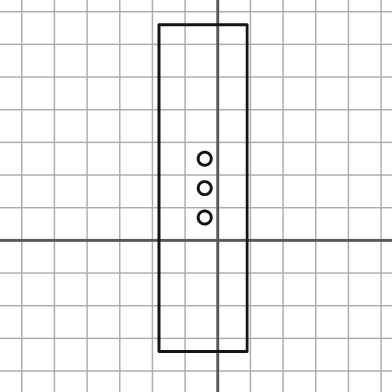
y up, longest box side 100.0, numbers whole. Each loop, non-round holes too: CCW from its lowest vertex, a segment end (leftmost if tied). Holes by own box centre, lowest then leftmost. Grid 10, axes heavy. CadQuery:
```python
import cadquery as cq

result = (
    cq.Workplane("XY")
    .moveTo(-18.0, -34.0)
    .lineTo(9.0, -34.0)
    .lineTo(9.0, 66.0)
    .lineTo(-18.0, 66.0)
    .close()
    .moveTo(-4.0, 7.0)
    .circle(2.0)
    .moveTo(-4.0, 16.0)
    .circle(2.0)
    .moveTo(-4.0, 25.0)
    .circle(2.0)
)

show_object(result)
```